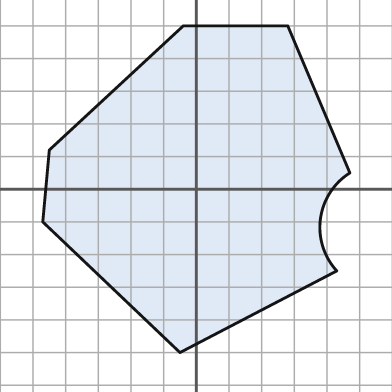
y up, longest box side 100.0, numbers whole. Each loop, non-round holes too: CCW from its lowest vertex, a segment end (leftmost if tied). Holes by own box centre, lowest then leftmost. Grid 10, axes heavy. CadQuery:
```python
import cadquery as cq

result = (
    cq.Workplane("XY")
    .moveTo(-5.0, -50.0)
    .lineTo(43.0, -25.0)
    .threePointArc((38.0, -9.0), (47.0, 5.0))
    .lineTo(28.0, 50.0)
    .lineTo(-4.0, 50.0)
    .lineTo(-45.0, 12.0)
    .lineTo(-47.0, -10.0)
    .close()
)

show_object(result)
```